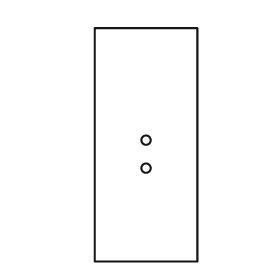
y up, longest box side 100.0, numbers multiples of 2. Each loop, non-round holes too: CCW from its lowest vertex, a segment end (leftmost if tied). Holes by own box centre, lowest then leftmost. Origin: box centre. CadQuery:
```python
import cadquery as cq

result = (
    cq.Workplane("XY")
    .moveTo(-22.0, -50.0)
    .lineTo(22.0, -50.0)
    .lineTo(22.0, 50.0)
    .lineTo(-22.0, 50.0)
    .close()
    .moveTo(0.0, -10.0)
    .circle(2.0)
    .moveTo(0.0, 2.0)
    .circle(2.0)
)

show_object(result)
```